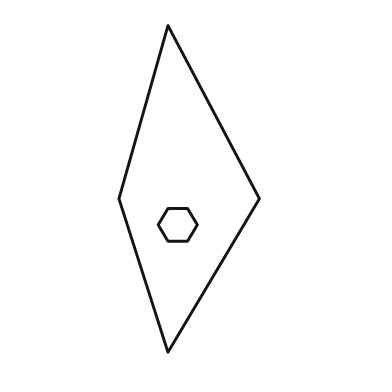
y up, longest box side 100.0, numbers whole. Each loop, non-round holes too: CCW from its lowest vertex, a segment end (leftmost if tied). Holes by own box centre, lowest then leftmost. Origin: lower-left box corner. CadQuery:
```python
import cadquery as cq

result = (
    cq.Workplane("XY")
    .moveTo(15.0, 0.0)
    .lineTo(43.0, 47.0)
    .lineTo(15.0, 100.0)
    .lineTo(0.0, 47.0)
    .close()
    .moveTo(15.0, 34.0)
    .lineTo(21.0, 34.0)
    .lineTo(24.0, 39.0)
    .lineTo(21.0, 44.0)
    .lineTo(15.0, 44.0)
    .lineTo(12.0, 39.0)
    .close()
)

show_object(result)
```